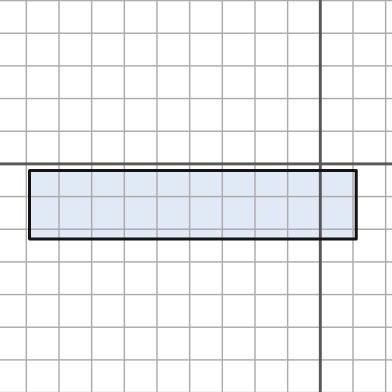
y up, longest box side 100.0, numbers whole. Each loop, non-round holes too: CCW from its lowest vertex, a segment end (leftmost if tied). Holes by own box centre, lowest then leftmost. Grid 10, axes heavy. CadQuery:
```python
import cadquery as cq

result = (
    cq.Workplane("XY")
    .moveTo(-89.0, -23.0)
    .lineTo(11.0, -23.0)
    .lineTo(11.0, -2.0)
    .lineTo(-89.0, -2.0)
    .close()
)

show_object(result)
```